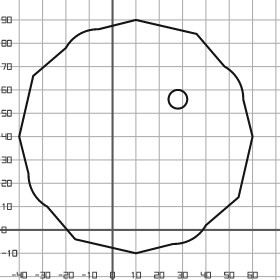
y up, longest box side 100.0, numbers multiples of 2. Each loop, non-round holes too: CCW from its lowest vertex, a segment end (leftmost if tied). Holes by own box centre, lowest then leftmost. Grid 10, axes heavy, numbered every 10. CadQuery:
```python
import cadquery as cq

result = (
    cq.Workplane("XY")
    .moveTo(10.0, -10.0)
    .lineTo(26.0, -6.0)
    .threePointArc((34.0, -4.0), (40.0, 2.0))
    .lineTo(54.0, 14.0)
    .lineTo(60.0, 40.0)
    .lineTo(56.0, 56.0)
    .threePointArc((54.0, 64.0), (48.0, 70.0))
    .lineTo(36.0, 84.0)
    .lineTo(10.0, 90.0)
    .lineTo(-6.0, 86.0)
    .threePointArc((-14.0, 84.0), (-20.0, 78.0))
    .lineTo(-34.0, 66.0)
    .lineTo(-40.0, 40.0)
    .lineTo(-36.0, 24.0)
    .threePointArc((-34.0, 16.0), (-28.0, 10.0))
    .lineTo(-16.0, -4.0)
    .close()
    .moveTo(28.0, 56.0)
    .circle(4.0)
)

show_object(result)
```